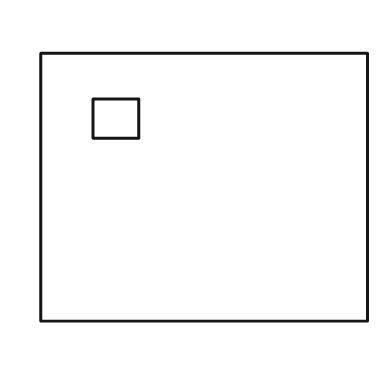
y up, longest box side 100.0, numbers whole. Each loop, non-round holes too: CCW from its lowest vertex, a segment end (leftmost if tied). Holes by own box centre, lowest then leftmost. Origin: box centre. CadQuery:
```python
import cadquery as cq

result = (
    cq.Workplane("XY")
    .moveTo(-50.0, -41.0)
    .lineTo(50.0, -41.0)
    .lineTo(50.0, 41.0)
    .lineTo(-50.0, 41.0)
    .close()
    .moveTo(-34.0, 15.0)
    .lineTo(-20.0, 15.0)
    .lineTo(-20.0, 27.0)
    .lineTo(-34.0, 27.0)
    .close()
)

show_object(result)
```